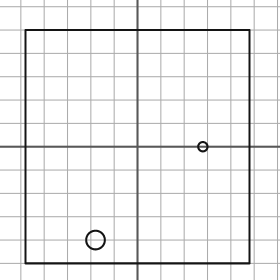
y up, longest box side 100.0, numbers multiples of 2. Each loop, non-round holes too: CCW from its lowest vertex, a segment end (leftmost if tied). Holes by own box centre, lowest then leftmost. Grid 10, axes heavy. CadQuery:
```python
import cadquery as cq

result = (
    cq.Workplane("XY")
    .moveTo(-48.0, -50.0)
    .lineTo(48.0, -50.0)
    .lineTo(48.0, 50.0)
    .lineTo(-48.0, 50.0)
    .close()
    .moveTo(-18.0, -40.0)
    .circle(4.0)
    .moveTo(28.0, 0.0)
    .circle(2.0)
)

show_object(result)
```